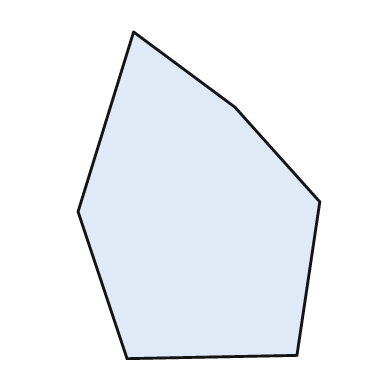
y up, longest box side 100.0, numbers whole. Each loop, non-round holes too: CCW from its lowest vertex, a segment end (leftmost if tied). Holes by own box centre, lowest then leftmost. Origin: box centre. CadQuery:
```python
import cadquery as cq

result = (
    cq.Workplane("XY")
    .moveTo(-22.0, -50.0)
    .lineTo(30.0, -49.0)
    .lineTo(37.0, -2.0)
    .lineTo(11.0, 27.0)
    .lineTo(-20.0, 50.0)
    .lineTo(-37.0, -5.0)
    .close()
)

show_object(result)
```